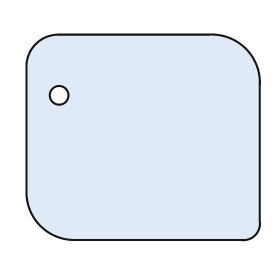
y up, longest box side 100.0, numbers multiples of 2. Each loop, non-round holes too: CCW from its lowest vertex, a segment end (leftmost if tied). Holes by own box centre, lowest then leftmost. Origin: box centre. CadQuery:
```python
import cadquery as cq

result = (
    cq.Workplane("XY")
    .moveTo(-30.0, -44.0)
    .lineTo(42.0, -44.0)
    .threePointArc((48.0, -42.0), (50.0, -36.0))
    .lineTo(50.0, 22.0)
    .threePointArc((44.0, 38.0), (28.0, 44.0))
    .lineTo(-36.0, 44.0)
    .threePointArc((-46.0, 40.0), (-50.0, 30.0))
    .lineTo(-50.0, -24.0)
    .threePointArc((-44.0, -38.0), (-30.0, -44.0))
    .close()
    .moveTo(-36.0, 18.0)
    .circle(4.0)
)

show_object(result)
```